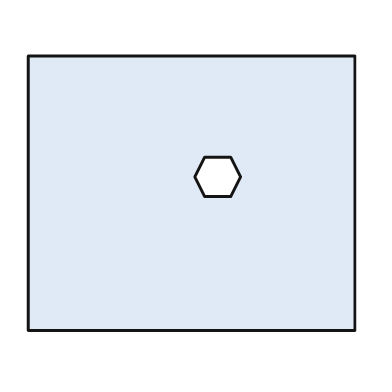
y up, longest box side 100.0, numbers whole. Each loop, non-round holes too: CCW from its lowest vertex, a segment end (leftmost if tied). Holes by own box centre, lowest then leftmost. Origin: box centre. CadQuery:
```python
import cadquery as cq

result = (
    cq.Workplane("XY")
    .moveTo(-50.0, -42.0)
    .lineTo(50.0, -42.0)
    .lineTo(50.0, 42.0)
    .lineTo(-50.0, 42.0)
    .close()
    .moveTo(4.0, -1.0)
    .lineTo(12.0, -1.0)
    .lineTo(15.0, 5.0)
    .lineTo(12.0, 11.0)
    .lineTo(4.0, 11.0)
    .lineTo(1.0, 5.0)
    .close()
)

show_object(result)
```